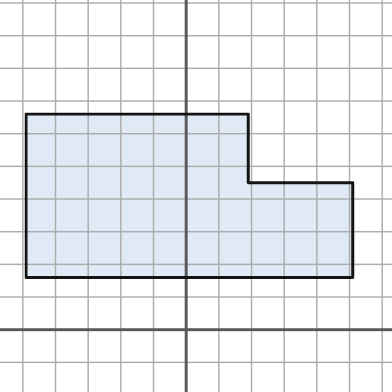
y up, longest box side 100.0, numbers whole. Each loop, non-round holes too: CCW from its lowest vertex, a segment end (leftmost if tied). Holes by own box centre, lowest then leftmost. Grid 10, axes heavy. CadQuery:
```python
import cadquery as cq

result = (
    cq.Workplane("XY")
    .moveTo(-49.0, 16.0)
    .lineTo(51.0, 16.0)
    .lineTo(51.0, 45.0)
    .lineTo(19.0, 45.0)
    .lineTo(19.0, 66.0)
    .lineTo(-49.0, 66.0)
    .close()
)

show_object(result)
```